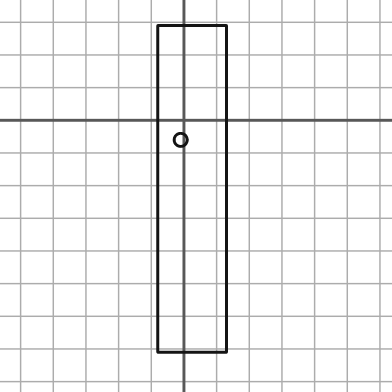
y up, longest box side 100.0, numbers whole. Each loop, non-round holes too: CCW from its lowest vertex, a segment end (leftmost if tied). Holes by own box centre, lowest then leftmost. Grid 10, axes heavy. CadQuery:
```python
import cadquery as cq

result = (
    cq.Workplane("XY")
    .moveTo(-8.0, -71.0)
    .lineTo(13.0, -71.0)
    .lineTo(13.0, 29.0)
    .lineTo(-8.0, 29.0)
    .close()
    .moveTo(-1.0, -6.0)
    .circle(2.0)
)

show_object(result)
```